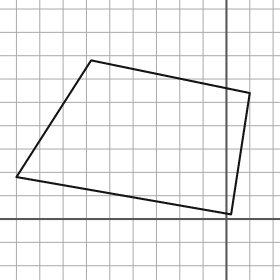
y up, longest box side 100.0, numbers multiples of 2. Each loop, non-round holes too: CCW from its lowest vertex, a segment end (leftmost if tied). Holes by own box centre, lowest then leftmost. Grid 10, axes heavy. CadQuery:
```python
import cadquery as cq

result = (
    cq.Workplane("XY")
    .moveTo(2.0, 2.0)
    .lineTo(10.0, 54.0)
    .lineTo(-58.0, 68.0)
    .lineTo(-90.0, 18.0)
    .close()
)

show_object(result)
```